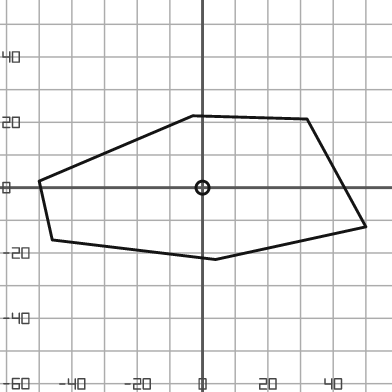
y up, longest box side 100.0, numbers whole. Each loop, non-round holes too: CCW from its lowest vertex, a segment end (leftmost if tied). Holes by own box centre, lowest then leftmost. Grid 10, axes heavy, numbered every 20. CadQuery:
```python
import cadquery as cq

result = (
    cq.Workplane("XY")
    .moveTo(4.0, -22.0)
    .lineTo(50.0, -12.0)
    .lineTo(32.0, 21.0)
    .lineTo(-3.0, 22.0)
    .lineTo(-50.0, 2.0)
    .lineTo(-46.0, -16.0)
    .close()
    .moveTo(0.0, 0.0)
    .circle(2.0)
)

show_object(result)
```